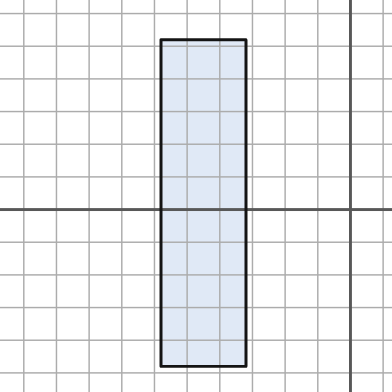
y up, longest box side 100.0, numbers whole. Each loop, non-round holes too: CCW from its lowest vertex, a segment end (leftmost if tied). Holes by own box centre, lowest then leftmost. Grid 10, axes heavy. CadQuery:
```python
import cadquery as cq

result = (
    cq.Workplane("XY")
    .moveTo(-58.0, -48.0)
    .lineTo(-32.0, -48.0)
    .lineTo(-32.0, 52.0)
    .lineTo(-58.0, 52.0)
    .close()
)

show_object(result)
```